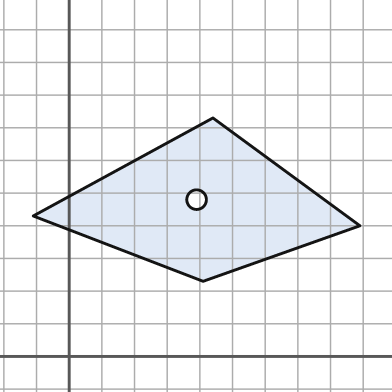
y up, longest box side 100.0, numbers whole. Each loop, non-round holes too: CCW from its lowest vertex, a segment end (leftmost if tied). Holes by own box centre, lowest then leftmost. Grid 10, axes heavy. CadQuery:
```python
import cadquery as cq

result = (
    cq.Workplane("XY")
    .moveTo(41.0, 23.0)
    .lineTo(89.0, 40.0)
    .lineTo(44.0, 73.0)
    .lineTo(-11.0, 43.0)
    .close()
    .moveTo(39.0, 48.0)
    .circle(3.0)
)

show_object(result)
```